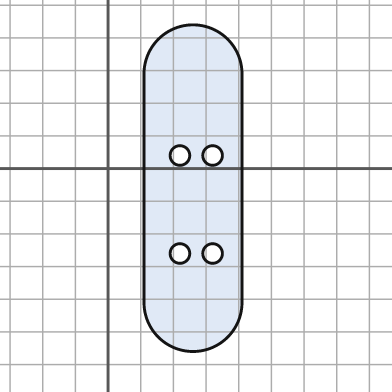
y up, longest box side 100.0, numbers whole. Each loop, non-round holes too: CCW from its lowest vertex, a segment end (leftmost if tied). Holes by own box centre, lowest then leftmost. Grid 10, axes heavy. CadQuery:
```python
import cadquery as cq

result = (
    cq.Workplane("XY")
    .moveTo(11.0, -41.0)
    .threePointArc((26.0, -56.0), (41.0, -41.0))
    .lineTo(41.0, 29.0)
    .threePointArc((26.0, 44.0), (11.0, 29.0))
    .close()
    .moveTo(22.0, -26.0)
    .circle(3.0)
    .moveTo(32.0, -26.0)
    .circle(3.0)
    .moveTo(22.0, 4.0)
    .circle(3.0)
    .moveTo(32.0, 4.0)
    .circle(3.0)
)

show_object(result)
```